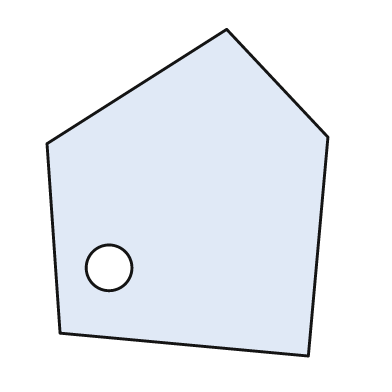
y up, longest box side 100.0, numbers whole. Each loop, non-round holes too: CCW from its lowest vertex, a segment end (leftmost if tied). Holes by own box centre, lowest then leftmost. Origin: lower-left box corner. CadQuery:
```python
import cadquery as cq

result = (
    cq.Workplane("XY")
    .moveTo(80.0, 0.0)
    .lineTo(86.0, 67.0)
    .lineTo(55.0, 100.0)
    .lineTo(0.0, 65.0)
    .lineTo(4.0, 7.0)
    .close()
    .moveTo(19.0, 27.0)
    .circle(7.0)
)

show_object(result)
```